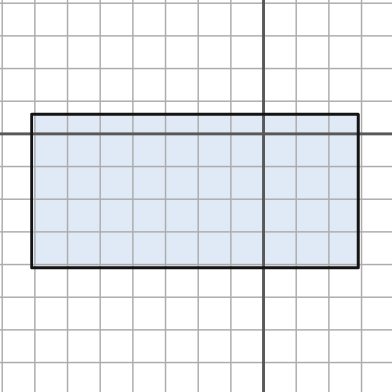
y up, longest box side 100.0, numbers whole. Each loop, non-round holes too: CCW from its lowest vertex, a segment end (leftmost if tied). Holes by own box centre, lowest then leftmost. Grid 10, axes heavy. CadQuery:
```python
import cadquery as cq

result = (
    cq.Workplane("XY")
    .moveTo(-71.0, -41.0)
    .lineTo(29.0, -41.0)
    .lineTo(29.0, 6.0)
    .lineTo(-71.0, 6.0)
    .close()
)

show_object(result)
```